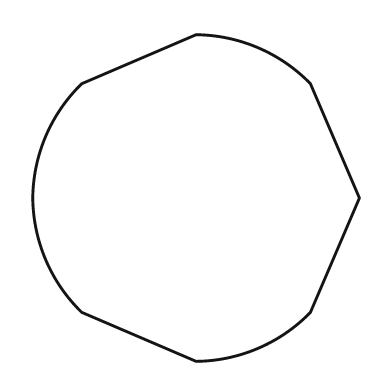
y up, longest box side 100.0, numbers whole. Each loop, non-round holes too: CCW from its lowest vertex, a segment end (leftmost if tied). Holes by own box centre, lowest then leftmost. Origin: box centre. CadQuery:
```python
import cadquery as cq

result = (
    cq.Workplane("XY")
    .moveTo(0.0, -50.0)
    .threePointArc((19.0, -46.0), (35.0, -35.0))
    .lineTo(50.0, 0.0)
    .lineTo(35.0, 35.0)
    .threePointArc((19.0, 46.0), (0.0, 50.0))
    .lineTo(-35.0, 35.0)
    .threePointArc((-46.0, 19.0), (-50.0, 0.0))
    .threePointArc((-46.0, -19.0), (-35.0, -35.0))
    .close()
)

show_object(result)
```